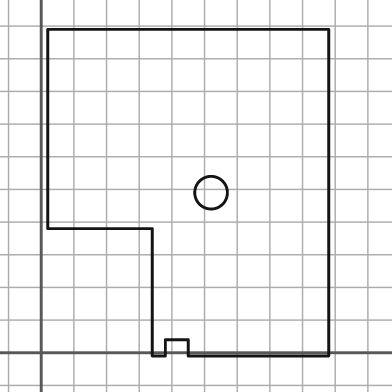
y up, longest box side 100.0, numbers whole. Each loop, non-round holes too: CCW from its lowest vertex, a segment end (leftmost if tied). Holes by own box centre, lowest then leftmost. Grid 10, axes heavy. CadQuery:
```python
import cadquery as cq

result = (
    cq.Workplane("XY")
    .moveTo(34.0, -1.0)
    .lineTo(38.0, -1.0)
    .lineTo(38.0, 4.0)
    .lineTo(45.0, 4.0)
    .lineTo(45.0, -1.0)
    .lineTo(88.0, -1.0)
    .lineTo(88.0, 99.0)
    .lineTo(2.0, 99.0)
    .lineTo(2.0, 38.0)
    .lineTo(34.0, 38.0)
    .close()
    .moveTo(52.0, 49.0)
    .circle(5.0)
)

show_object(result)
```